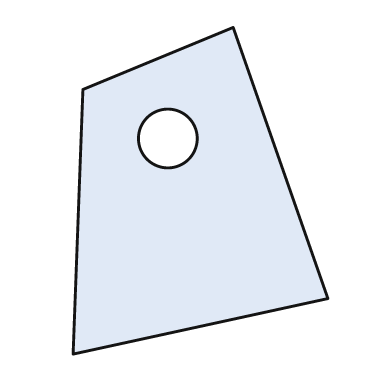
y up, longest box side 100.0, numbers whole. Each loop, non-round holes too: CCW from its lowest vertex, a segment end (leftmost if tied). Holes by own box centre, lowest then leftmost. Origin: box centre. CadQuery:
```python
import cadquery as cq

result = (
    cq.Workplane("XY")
    .moveTo(-39.0, -50.0)
    .lineTo(39.0, -33.0)
    .lineTo(10.0, 50.0)
    .lineTo(-36.0, 31.0)
    .close()
    .moveTo(-10.0, 16.0)
    .circle(9.0)
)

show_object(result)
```